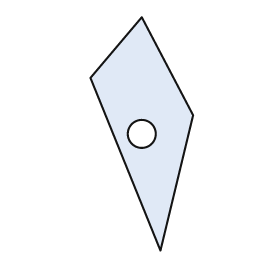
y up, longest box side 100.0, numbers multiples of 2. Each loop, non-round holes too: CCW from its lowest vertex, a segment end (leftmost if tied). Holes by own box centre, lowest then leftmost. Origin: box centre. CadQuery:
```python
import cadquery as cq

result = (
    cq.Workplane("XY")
    .moveTo(8.0, -50.0)
    .lineTo(22.0, 8.0)
    .lineTo(0.0, 50.0)
    .lineTo(-22.0, 24.0)
    .close()
    .moveTo(0.0, 0.0)
    .circle(6.0)
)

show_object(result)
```